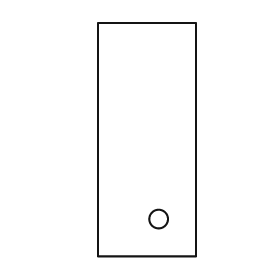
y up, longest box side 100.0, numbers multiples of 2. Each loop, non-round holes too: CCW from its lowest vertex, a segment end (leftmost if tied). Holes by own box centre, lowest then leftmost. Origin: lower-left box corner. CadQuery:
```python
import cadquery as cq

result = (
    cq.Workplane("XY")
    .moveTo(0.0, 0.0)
    .lineTo(42.0, 0.0)
    .lineTo(42.0, 100.0)
    .lineTo(0.0, 100.0)
    .close()
    .moveTo(26.0, 16.0)
    .circle(4.0)
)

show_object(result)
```